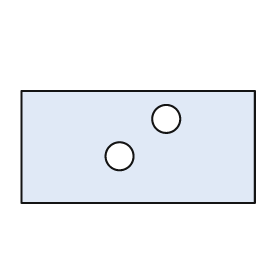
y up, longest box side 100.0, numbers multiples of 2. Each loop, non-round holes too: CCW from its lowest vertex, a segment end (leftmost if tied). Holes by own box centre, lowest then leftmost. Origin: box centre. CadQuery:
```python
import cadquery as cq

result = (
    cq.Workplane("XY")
    .moveTo(-50.0, -24.0)
    .lineTo(50.0, -24.0)
    .lineTo(50.0, 24.0)
    .lineTo(-50.0, 24.0)
    .close()
    .moveTo(-8.0, -4.0)
    .circle(6.0)
    .moveTo(12.0, 12.0)
    .circle(6.0)
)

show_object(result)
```